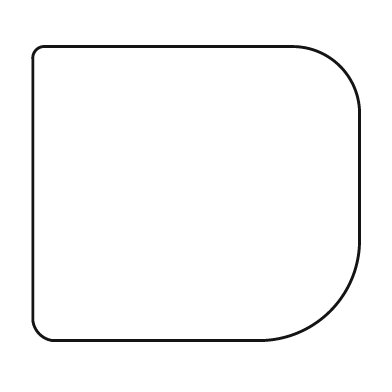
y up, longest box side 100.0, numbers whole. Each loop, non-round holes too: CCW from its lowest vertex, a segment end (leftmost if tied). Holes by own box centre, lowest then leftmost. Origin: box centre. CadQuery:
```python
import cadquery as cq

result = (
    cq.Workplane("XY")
    .moveTo(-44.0, -45.0)
    .lineTo(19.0, -45.0)
    .threePointArc((41.0, -36.0), (50.0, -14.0))
    .lineTo(50.0, 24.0)
    .threePointArc((44.0, 39.0), (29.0, 45.0))
    .lineTo(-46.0, 45.0)
    .threePointArc((-49.0, 44.0), (-50.0, 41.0))
    .lineTo(-50.0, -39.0)
    .threePointArc((-48.0, -43.0), (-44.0, -45.0))
    .close()
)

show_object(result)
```